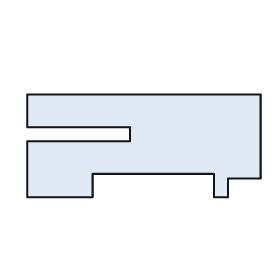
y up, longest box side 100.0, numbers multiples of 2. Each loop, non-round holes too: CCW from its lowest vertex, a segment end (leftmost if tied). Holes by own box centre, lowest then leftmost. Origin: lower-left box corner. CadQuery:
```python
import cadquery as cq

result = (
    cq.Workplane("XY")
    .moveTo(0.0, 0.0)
    .lineTo(28.0, 0.0)
    .lineTo(28.0, 10.0)
    .lineTo(80.0, 10.0)
    .lineTo(80.0, 0.0)
    .lineTo(86.0, 0.0)
    .lineTo(86.0, 8.0)
    .lineTo(100.0, 8.0)
    .lineTo(100.0, 44.0)
    .lineTo(0.0, 44.0)
    .lineTo(0.0, 30.0)
    .lineTo(44.0, 30.0)
    .lineTo(44.0, 24.0)
    .lineTo(0.0, 24.0)
    .close()
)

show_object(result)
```